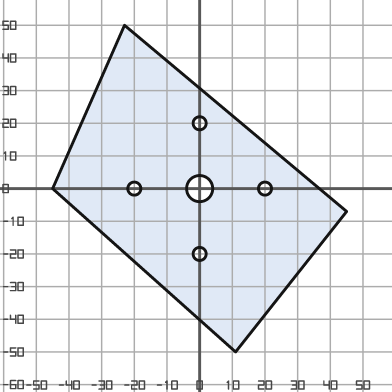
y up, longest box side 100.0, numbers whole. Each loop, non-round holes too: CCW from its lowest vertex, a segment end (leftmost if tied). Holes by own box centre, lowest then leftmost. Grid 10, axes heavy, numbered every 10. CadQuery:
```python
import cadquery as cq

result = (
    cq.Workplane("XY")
    .moveTo(11.0, -50.0)
    .lineTo(45.0, -7.0)
    .lineTo(-23.0, 50.0)
    .lineTo(-45.0, 0.0)
    .close()
    .moveTo(0.0, -20.0)
    .circle(2.0)
    .moveTo(-20.0, 0.0)
    .circle(2.0)
    .moveTo(0.0, 0.0)
    .circle(4.0)
    .moveTo(20.0, 0.0)
    .circle(2.0)
    .moveTo(0.0, 20.0)
    .circle(2.0)
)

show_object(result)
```